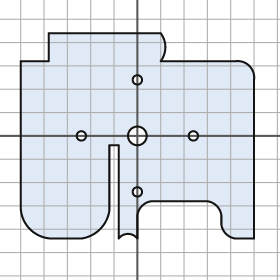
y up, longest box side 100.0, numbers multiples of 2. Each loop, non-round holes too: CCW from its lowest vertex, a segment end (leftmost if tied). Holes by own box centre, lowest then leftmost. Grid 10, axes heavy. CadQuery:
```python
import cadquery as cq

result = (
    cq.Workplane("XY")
    .moveTo(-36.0, -44.0)
    .lineTo(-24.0, -44.0)
    .threePointArc((-16.0, -40.0), (-12.0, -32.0))
    .lineTo(-12.0, -4.0)
    .lineTo(-8.0, -4.0)
    .lineTo(-8.0, -44.0)
    .threePointArc((-4.0, -42.0), (0.0, -44.0))
    .lineTo(0.0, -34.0)
    .threePointArc((2.0, -30.0), (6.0, -28.0))
    .lineTo(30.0, -28.0)
    .threePointArc((34.0, -30.0), (36.0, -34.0))
    .lineTo(36.0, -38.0)
    .threePointArc((38.0, -42.0), (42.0, -44.0))
    .lineTo(50.0, -44.0)
    .lineTo(50.0, 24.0)
    .threePointArc((48.0, 30.0), (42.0, 32.0))
    .lineTo(10.0, 32.0)
    .threePointArc((12.0, 38.0), (10.0, 44.0))
    .lineTo(-38.0, 44.0)
    .lineTo(-38.0, 32.0)
    .lineTo(-50.0, 32.0)
    .lineTo(-50.0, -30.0)
    .threePointArc((-46.0, -40.0), (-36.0, -44.0))
    .close()
    .moveTo(0.0, -24.0)
    .circle(2.0)
    .moveTo(-24.0, 0.0)
    .circle(2.0)
    .moveTo(0.0, 0.0)
    .circle(4.0)
    .moveTo(24.0, 0.0)
    .circle(2.0)
    .moveTo(0.0, 24.0)
    .circle(2.0)
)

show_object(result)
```